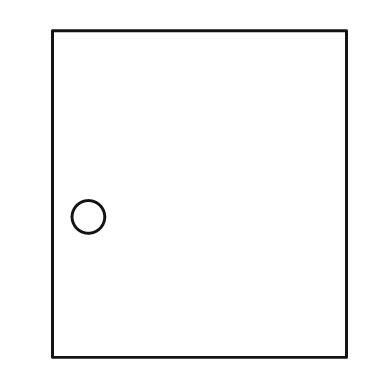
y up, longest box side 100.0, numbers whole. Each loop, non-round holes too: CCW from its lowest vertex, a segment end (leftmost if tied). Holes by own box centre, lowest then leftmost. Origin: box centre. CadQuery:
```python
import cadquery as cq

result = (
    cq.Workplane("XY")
    .moveTo(-45.0, -50.0)
    .lineTo(45.0, -50.0)
    .lineTo(45.0, 50.0)
    .lineTo(-45.0, 50.0)
    .close()
    .moveTo(-34.0, -7.0)
    .circle(5.0)
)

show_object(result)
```